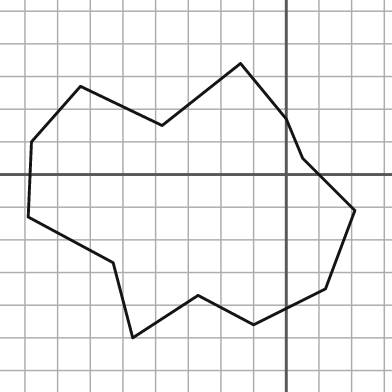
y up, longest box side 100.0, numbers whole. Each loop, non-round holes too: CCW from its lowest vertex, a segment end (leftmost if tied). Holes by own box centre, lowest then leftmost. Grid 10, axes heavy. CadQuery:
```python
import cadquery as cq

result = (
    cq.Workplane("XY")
    .moveTo(-47.0, -50.0)
    .lineTo(-27.0, -37.0)
    .lineTo(-10.0, -46.0)
    .lineTo(12.0, -35.0)
    .lineTo(21.0, -11.0)
    .lineTo(5.0, 5.0)
    .lineTo(0.0, 17.0)
    .lineTo(-14.0, 34.0)
    .lineTo(-38.0, 15.0)
    .lineTo(-63.0, 27.0)
    .lineTo(-78.0, 10.0)
    .lineTo(-79.0, -13.0)
    .lineTo(-53.0, -27.0)
    .close()
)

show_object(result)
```